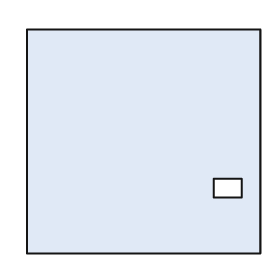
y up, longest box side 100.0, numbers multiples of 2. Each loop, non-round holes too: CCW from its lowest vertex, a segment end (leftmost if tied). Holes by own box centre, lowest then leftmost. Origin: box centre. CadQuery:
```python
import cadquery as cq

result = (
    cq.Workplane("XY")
    .moveTo(-50.0, -48.0)
    .lineTo(50.0, -48.0)
    .lineTo(50.0, 48.0)
    .lineTo(-50.0, 48.0)
    .close()
    .moveTo(30.0, -24.0)
    .lineTo(42.0, -24.0)
    .lineTo(42.0, -16.0)
    .lineTo(30.0, -16.0)
    .close()
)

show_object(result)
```